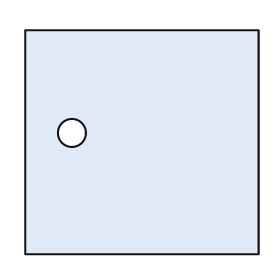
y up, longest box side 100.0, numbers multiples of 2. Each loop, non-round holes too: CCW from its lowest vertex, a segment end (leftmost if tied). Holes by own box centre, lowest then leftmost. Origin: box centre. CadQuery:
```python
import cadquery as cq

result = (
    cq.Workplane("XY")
    .moveTo(-50.0, -48.0)
    .lineTo(50.0, -48.0)
    .lineTo(50.0, 48.0)
    .lineTo(-50.0, 48.0)
    .close()
    .moveTo(-30.0, 4.0)
    .circle(6.0)
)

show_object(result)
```